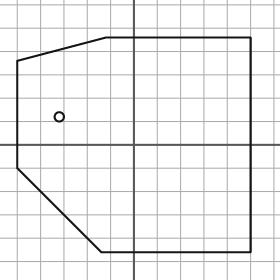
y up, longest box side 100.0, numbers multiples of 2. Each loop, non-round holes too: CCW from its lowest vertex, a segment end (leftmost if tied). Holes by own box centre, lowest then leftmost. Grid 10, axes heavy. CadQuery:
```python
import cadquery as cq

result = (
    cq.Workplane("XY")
    .moveTo(-14.0, -46.0)
    .lineTo(50.0, -46.0)
    .lineTo(50.0, 46.0)
    .lineTo(-12.0, 46.0)
    .lineTo(-50.0, 36.0)
    .lineTo(-50.0, -10.0)
    .close()
    .moveTo(-32.0, 12.0)
    .circle(2.0)
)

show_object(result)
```